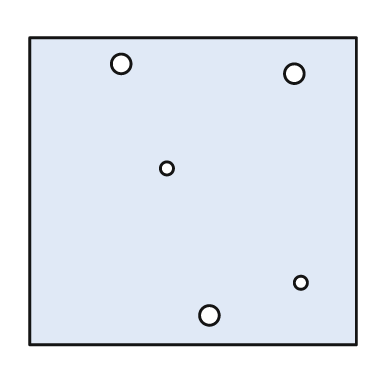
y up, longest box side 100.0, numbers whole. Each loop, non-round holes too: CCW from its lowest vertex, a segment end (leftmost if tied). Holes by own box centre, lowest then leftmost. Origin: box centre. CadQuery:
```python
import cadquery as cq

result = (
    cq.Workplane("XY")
    .moveTo(-50.0, -47.0)
    .lineTo(50.0, -47.0)
    .lineTo(50.0, 47.0)
    .lineTo(-50.0, 47.0)
    .close()
    .moveTo(5.0, -38.0)
    .circle(3.0)
    .moveTo(33.0, -28.0)
    .circle(2.0)
    .moveTo(-8.0, 7.0)
    .circle(2.0)
    .moveTo(31.0, 36.0)
    .circle(3.0)
    .moveTo(-22.0, 39.0)
    .circle(3.0)
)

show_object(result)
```